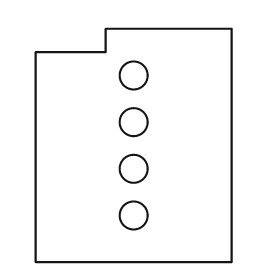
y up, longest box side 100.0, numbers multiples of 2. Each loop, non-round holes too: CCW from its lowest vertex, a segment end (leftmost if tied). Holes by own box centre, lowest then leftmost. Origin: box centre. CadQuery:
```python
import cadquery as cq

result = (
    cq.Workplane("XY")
    .moveTo(-42.0, -50.0)
    .lineTo(42.0, -50.0)
    .lineTo(42.0, 50.0)
    .lineTo(-12.0, 50.0)
    .lineTo(-12.0, 40.0)
    .lineTo(-42.0, 40.0)
    .close()
    .moveTo(0.0, -30.0)
    .circle(6.0)
    .moveTo(0.0, -10.0)
    .circle(6.0)
    .moveTo(0.0, 10.0)
    .circle(6.0)
    .moveTo(0.0, 30.0)
    .circle(6.0)
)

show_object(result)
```